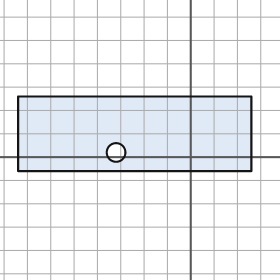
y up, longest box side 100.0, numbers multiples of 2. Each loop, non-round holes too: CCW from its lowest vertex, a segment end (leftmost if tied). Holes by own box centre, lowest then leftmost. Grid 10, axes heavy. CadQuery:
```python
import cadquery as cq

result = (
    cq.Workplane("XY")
    .moveTo(-74.0, -6.0)
    .lineTo(26.0, -6.0)
    .lineTo(26.0, 26.0)
    .lineTo(-74.0, 26.0)
    .close()
    .moveTo(-32.0, 2.0)
    .circle(4.0)
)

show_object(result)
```